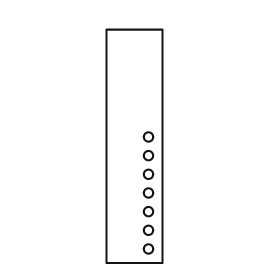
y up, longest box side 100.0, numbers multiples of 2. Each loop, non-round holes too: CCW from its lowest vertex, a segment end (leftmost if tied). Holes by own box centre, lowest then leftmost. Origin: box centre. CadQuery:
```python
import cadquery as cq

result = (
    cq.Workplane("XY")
    .moveTo(-12.0, -50.0)
    .lineTo(12.0, -50.0)
    .lineTo(12.0, 50.0)
    .lineTo(-12.0, 50.0)
    .close()
    .moveTo(6.0, -44.0)
    .circle(2.0)
    .moveTo(6.0, -36.0)
    .circle(2.0)
    .moveTo(6.0, -28.0)
    .circle(2.0)
    .moveTo(6.0, -20.0)
    .circle(2.0)
    .moveTo(6.0, -12.0)
    .circle(2.0)
    .moveTo(6.0, -4.0)
    .circle(2.0)
    .moveTo(6.0, 4.0)
    .circle(2.0)
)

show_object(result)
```